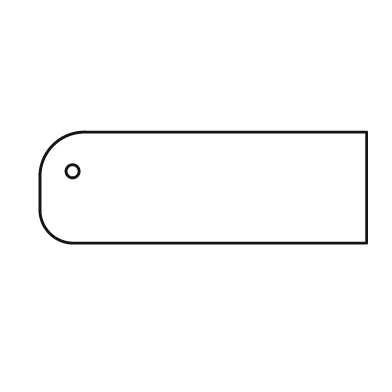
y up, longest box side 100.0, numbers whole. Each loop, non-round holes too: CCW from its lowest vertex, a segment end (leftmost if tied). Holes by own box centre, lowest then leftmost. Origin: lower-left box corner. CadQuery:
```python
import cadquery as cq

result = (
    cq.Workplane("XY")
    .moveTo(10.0, 0.0)
    .lineTo(100.0, 0.0)
    .lineTo(100.0, 34.0)
    .lineTo(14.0, 34.0)
    .threePointArc((4.0, 30.0), (0.0, 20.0))
    .lineTo(0.0, 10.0)
    .threePointArc((3.0, 3.0), (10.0, 0.0))
    .close()
    .moveTo(10.0, 22.0)
    .circle(2.0)
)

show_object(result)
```